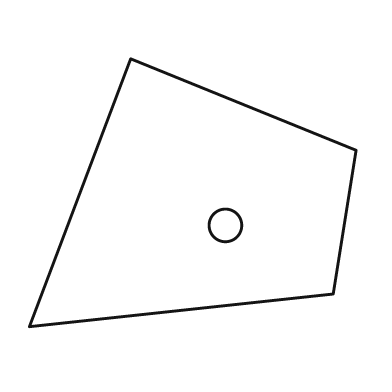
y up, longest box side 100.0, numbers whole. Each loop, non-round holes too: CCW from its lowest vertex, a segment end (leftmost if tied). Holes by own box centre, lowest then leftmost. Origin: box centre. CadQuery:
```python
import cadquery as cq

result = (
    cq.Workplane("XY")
    .moveTo(-50.0, -41.0)
    .lineTo(43.0, -31.0)
    .lineTo(50.0, 13.0)
    .lineTo(-19.0, 41.0)
    .close()
    .moveTo(10.0, -10.0)
    .circle(5.0)
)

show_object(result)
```